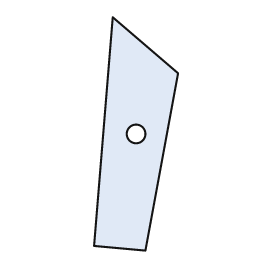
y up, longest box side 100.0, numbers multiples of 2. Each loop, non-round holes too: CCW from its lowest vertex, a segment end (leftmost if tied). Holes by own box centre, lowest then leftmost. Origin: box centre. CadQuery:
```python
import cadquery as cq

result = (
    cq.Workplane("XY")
    .moveTo(4.0, -50.0)
    .lineTo(18.0, 26.0)
    .lineTo(-10.0, 50.0)
    .lineTo(-18.0, -48.0)
    .close()
    .moveTo(0.0, 0.0)
    .circle(4.0)
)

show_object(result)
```